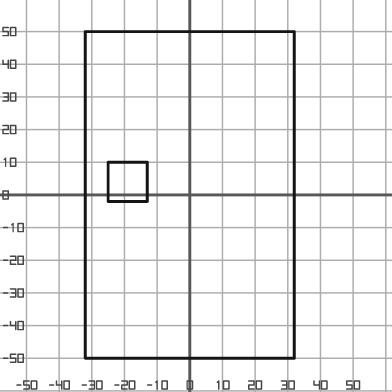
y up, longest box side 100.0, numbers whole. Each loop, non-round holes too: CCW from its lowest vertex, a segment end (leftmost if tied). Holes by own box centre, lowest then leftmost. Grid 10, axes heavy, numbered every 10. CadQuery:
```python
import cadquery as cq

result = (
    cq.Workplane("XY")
    .moveTo(-32.0, -50.0)
    .lineTo(32.0, -50.0)
    .lineTo(32.0, 50.0)
    .lineTo(-32.0, 50.0)
    .close()
    .moveTo(-25.0, -2.0)
    .lineTo(-13.0, -2.0)
    .lineTo(-13.0, 10.0)
    .lineTo(-25.0, 10.0)
    .close()
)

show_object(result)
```